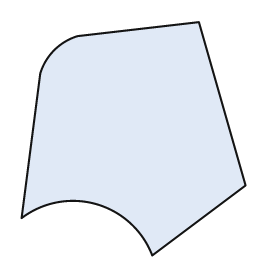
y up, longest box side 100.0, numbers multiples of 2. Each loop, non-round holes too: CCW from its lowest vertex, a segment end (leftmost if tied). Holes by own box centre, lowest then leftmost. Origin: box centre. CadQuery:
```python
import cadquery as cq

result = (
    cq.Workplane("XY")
    .moveTo(8.0, -50.0)
    .lineTo(48.0, -20.0)
    .lineTo(28.0, 50.0)
    .lineTo(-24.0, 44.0)
    .threePointArc((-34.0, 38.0), (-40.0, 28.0))
    .lineTo(-48.0, -34.0)
    .threePointArc((-16.0, -28.0), (8.0, -50.0))
    .close()
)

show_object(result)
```